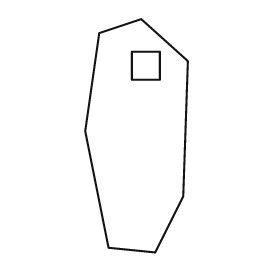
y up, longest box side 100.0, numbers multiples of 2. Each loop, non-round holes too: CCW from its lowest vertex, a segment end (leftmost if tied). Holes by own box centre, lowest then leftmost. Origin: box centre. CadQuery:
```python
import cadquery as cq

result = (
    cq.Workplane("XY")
    .moveTo(8.0, -50.0)
    .lineTo(20.0, -26.0)
    .lineTo(22.0, 32.0)
    .lineTo(2.0, 50.0)
    .lineTo(-16.0, 44.0)
    .lineTo(-22.0, 2.0)
    .lineTo(-12.0, -48.0)
    .close()
    .moveTo(-2.0, 24.0)
    .lineTo(10.0, 24.0)
    .lineTo(10.0, 36.0)
    .lineTo(-2.0, 36.0)
    .close()
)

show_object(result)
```